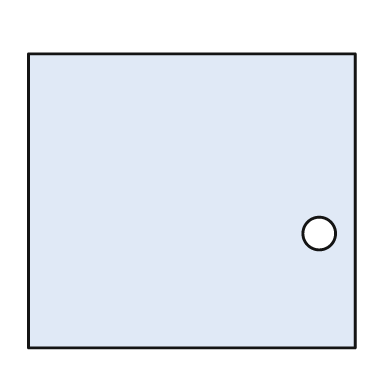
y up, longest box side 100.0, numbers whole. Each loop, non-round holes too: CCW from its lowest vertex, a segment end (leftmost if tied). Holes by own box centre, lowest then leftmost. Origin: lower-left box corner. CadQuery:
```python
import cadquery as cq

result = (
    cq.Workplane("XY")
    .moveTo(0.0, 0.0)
    .lineTo(100.0, 0.0)
    .lineTo(100.0, 90.0)
    .lineTo(0.0, 90.0)
    .close()
    .moveTo(89.0, 35.0)
    .circle(5.0)
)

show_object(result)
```